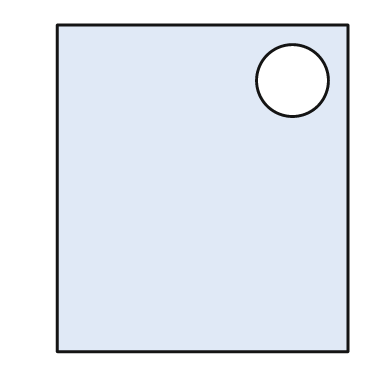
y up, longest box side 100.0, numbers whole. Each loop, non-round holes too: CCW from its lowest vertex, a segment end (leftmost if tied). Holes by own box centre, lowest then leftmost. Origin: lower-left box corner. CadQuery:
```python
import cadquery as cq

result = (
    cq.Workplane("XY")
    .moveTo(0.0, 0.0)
    .lineTo(89.0, 0.0)
    .lineTo(89.0, 100.0)
    .lineTo(0.0, 100.0)
    .close()
    .moveTo(72.0, 83.0)
    .circle(11.0)
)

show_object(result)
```